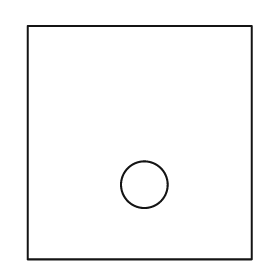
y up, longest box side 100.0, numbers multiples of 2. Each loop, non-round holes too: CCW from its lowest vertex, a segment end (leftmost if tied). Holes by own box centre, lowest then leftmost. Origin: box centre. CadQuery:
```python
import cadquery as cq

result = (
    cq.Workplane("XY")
    .moveTo(-48.0, -50.0)
    .lineTo(48.0, -50.0)
    .lineTo(48.0, 50.0)
    .lineTo(-48.0, 50.0)
    .close()
    .moveTo(2.0, -18.0)
    .circle(10.0)
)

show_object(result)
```